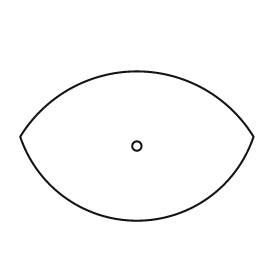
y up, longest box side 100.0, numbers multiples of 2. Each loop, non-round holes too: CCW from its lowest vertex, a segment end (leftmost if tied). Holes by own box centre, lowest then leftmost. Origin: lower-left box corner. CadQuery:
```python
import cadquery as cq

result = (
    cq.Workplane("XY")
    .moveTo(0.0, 36.0)
    .threePointArc((50.0, 0.0), (100.0, 36.0))
    .threePointArc((50.0, 64.0), (0.0, 36.0))
    .close()
    .moveTo(50.0, 32.0)
    .circle(2.0)
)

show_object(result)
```